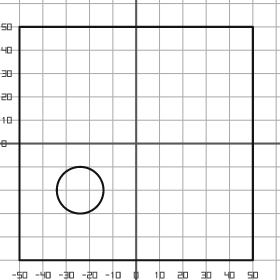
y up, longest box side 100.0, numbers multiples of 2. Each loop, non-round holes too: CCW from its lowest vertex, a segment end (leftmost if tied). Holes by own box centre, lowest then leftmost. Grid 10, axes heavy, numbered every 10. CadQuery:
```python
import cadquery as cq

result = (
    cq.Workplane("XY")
    .moveTo(-50.0, -50.0)
    .lineTo(50.0, -50.0)
    .lineTo(50.0, 50.0)
    .lineTo(-50.0, 50.0)
    .close()
    .moveTo(-24.0, -20.0)
    .circle(10.0)
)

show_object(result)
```